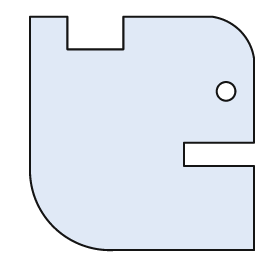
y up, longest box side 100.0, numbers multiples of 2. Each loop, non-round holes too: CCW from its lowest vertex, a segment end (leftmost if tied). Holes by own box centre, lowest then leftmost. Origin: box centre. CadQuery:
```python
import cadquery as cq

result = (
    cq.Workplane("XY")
    .moveTo(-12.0, -50.0)
    .lineTo(48.0, -50.0)
    .lineTo(48.0, -14.0)
    .lineTo(18.0, -14.0)
    .lineTo(18.0, -4.0)
    .lineTo(48.0, -4.0)
    .lineTo(48.0, 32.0)
    .threePointArc((42.0, 44.0), (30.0, 50.0))
    .lineTo(-8.0, 50.0)
    .lineTo(-8.0, 36.0)
    .lineTo(-32.0, 36.0)
    .lineTo(-32.0, 50.0)
    .lineTo(-48.0, 50.0)
    .lineTo(-48.0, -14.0)
    .threePointArc((-38.0, -40.0), (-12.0, -50.0))
    .close()
    .moveTo(36.0, 18.0)
    .circle(4.0)
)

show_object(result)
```